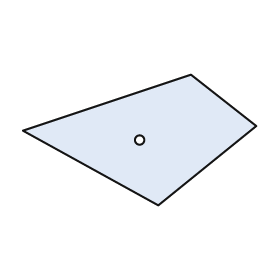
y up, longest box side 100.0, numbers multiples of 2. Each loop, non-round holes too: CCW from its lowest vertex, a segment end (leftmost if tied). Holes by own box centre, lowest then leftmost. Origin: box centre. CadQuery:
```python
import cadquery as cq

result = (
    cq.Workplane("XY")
    .moveTo(8.0, -28.0)
    .lineTo(50.0, 6.0)
    .lineTo(22.0, 28.0)
    .lineTo(-50.0, 4.0)
    .close()
    .moveTo(0.0, 0.0)
    .circle(2.0)
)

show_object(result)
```